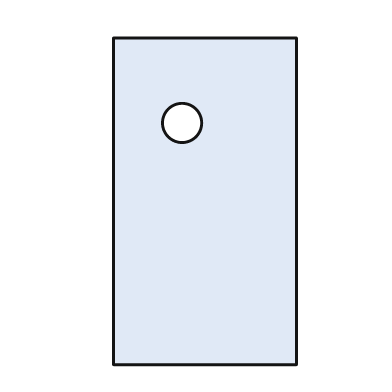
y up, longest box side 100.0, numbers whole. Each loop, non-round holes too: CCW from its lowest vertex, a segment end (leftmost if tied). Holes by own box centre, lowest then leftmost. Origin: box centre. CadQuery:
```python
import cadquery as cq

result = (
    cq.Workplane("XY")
    .moveTo(-28.0, -50.0)
    .lineTo(28.0, -50.0)
    .lineTo(28.0, 50.0)
    .lineTo(-28.0, 50.0)
    .close()
    .moveTo(-7.0, 24.0)
    .circle(6.0)
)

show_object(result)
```